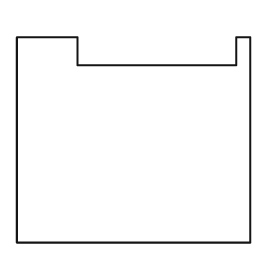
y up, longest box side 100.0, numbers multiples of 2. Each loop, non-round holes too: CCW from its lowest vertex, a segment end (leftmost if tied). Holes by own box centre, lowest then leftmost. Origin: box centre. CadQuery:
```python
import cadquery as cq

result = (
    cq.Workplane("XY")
    .moveTo(-50.0, -44.0)
    .lineTo(50.0, -44.0)
    .lineTo(50.0, 44.0)
    .lineTo(44.0, 44.0)
    .lineTo(44.0, 32.0)
    .lineTo(-24.0, 32.0)
    .lineTo(-24.0, 44.0)
    .lineTo(-50.0, 44.0)
    .close()
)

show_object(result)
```